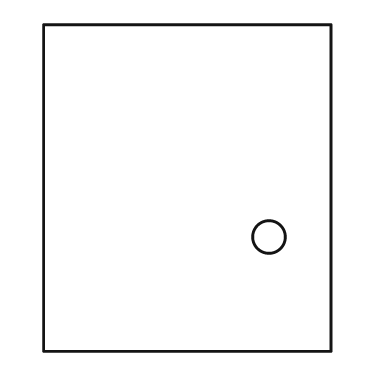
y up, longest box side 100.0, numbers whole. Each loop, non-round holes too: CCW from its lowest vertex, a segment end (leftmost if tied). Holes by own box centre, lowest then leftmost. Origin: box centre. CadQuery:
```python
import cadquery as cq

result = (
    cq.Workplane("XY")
    .moveTo(-44.0, -50.0)
    .lineTo(44.0, -50.0)
    .lineTo(44.0, 50.0)
    .lineTo(-44.0, 50.0)
    .close()
    .moveTo(25.0, -15.0)
    .circle(5.0)
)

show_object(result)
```